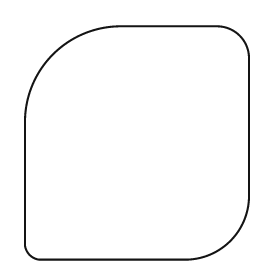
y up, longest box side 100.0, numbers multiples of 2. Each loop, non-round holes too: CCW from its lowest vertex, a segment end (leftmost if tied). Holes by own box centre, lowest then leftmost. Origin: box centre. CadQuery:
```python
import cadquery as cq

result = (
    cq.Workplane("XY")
    .moveTo(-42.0, -50.0)
    .lineTo(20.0, -50.0)
    .threePointArc((40.0, -42.0), (48.0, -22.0))
    .lineTo(48.0, 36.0)
    .threePointArc((44.0, 46.0), (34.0, 50.0))
    .lineTo(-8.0, 50.0)
    .threePointArc((-36.0, 38.0), (-48.0, 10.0))
    .lineTo(-48.0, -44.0)
    .threePointArc((-46.0, -48.0), (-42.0, -50.0))
    .close()
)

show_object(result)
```